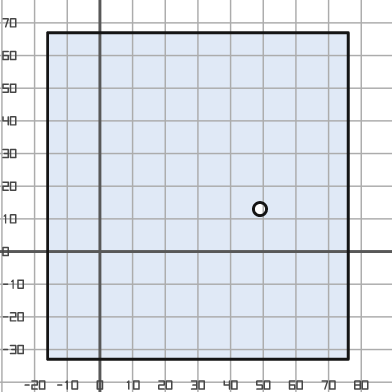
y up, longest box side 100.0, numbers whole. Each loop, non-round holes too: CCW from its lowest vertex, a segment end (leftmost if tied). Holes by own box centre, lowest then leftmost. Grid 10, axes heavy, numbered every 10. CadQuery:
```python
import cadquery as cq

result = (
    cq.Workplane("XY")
    .moveTo(-16.0, -33.0)
    .lineTo(76.0, -33.0)
    .lineTo(76.0, 67.0)
    .lineTo(-16.0, 67.0)
    .close()
    .moveTo(49.0, 13.0)
    .circle(2.0)
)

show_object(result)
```